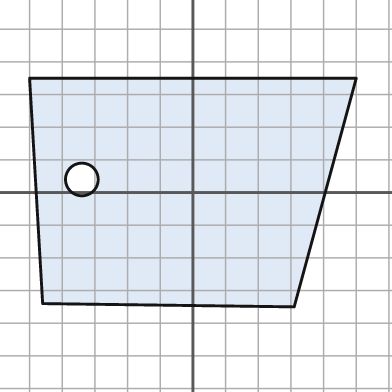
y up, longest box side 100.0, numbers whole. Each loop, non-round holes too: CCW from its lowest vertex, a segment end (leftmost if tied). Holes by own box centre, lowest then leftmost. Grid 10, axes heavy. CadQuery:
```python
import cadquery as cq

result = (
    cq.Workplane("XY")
    .moveTo(31.0, -35.0)
    .lineTo(50.0, 35.0)
    .lineTo(-50.0, 35.0)
    .lineTo(-46.0, -34.0)
    .close()
    .moveTo(-34.0, 4.0)
    .circle(5.0)
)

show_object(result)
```